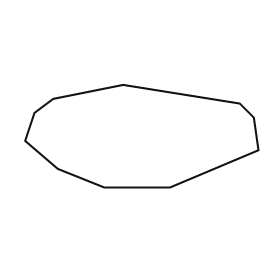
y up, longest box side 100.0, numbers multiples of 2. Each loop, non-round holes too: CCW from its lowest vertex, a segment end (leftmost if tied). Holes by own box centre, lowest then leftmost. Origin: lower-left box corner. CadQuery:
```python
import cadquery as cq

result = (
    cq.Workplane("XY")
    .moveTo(34.0, 0.0)
    .lineTo(62.0, 0.0)
    .lineTo(100.0, 16.0)
    .lineTo(98.0, 30.0)
    .lineTo(92.0, 36.0)
    .lineTo(42.0, 44.0)
    .lineTo(12.0, 38.0)
    .lineTo(4.0, 32.0)
    .lineTo(0.0, 20.0)
    .lineTo(14.0, 8.0)
    .close()
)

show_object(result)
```